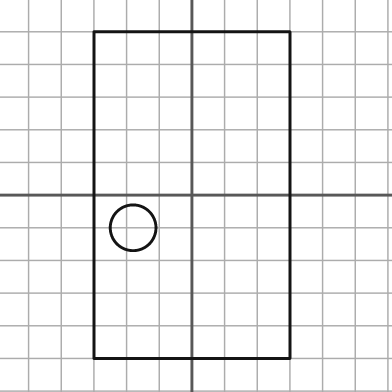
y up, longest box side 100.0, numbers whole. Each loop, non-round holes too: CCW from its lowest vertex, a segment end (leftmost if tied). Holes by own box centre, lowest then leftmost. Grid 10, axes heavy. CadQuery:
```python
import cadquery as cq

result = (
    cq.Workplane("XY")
    .moveTo(-30.0, -50.0)
    .lineTo(30.0, -50.0)
    .lineTo(30.0, 50.0)
    .lineTo(-30.0, 50.0)
    .close()
    .moveTo(-18.0, -10.0)
    .circle(7.0)
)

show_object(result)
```